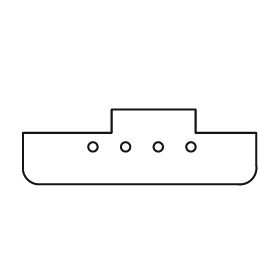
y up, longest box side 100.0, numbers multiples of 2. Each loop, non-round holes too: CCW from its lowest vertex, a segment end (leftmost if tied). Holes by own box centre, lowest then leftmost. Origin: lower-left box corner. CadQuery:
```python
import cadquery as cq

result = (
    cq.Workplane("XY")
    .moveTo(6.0, 0.0)
    .lineTo(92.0, 0.0)
    .threePointArc((98.0, 2.0), (100.0, 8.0))
    .lineTo(100.0, 22.0)
    .lineTo(74.0, 22.0)
    .lineTo(74.0, 32.0)
    .lineTo(38.0, 32.0)
    .lineTo(38.0, 22.0)
    .lineTo(0.0, 22.0)
    .lineTo(0.0, 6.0)
    .threePointArc((2.0, 2.0), (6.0, 0.0))
    .close()
    .moveTo(30.0, 16.0)
    .circle(2.0)
    .moveTo(44.0, 16.0)
    .circle(2.0)
    .moveTo(58.0, 16.0)
    .circle(2.0)
    .moveTo(72.0, 16.0)
    .circle(2.0)
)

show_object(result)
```